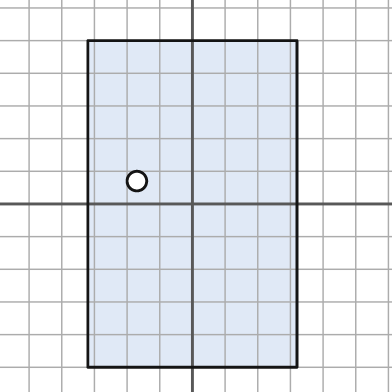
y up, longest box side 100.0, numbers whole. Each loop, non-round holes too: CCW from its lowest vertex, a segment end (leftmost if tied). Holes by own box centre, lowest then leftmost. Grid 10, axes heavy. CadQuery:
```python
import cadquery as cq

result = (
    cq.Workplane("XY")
    .moveTo(-32.0, -50.0)
    .lineTo(32.0, -50.0)
    .lineTo(32.0, 50.0)
    .lineTo(-32.0, 50.0)
    .close()
    .moveTo(-17.0, 7.0)
    .circle(3.0)
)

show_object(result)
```